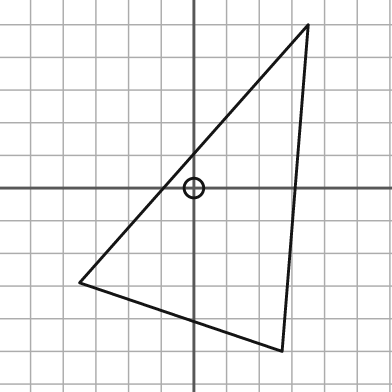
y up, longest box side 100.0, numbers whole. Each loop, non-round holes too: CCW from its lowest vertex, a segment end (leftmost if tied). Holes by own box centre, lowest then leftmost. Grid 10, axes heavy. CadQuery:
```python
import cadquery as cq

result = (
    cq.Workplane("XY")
    .moveTo(27.0, -50.0)
    .lineTo(35.0, 50.0)
    .lineTo(-35.0, -29.0)
    .close()
    .moveTo(0.0, 0.0)
    .circle(3.0)
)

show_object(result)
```